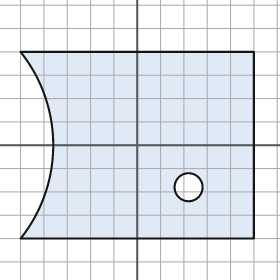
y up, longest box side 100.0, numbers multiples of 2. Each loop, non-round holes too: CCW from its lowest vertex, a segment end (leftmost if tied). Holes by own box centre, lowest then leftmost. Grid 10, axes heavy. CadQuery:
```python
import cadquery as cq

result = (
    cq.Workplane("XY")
    .moveTo(-50.0, -40.0)
    .lineTo(50.0, -40.0)
    .lineTo(50.0, 40.0)
    .lineTo(-50.0, 40.0)
    .threePointArc((-36.0, 0.0), (-50.0, -40.0))
    .close()
    .moveTo(22.0, -18.0)
    .circle(6.0)
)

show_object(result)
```